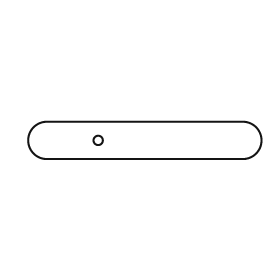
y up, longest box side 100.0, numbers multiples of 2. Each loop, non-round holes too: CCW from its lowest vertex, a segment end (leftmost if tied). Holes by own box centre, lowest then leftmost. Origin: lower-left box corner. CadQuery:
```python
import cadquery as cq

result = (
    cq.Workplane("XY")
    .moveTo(8.0, 0.0)
    .lineTo(92.0, 0.0)
    .threePointArc((100.0, 8.0), (92.0, 16.0))
    .lineTo(8.0, 16.0)
    .threePointArc((0.0, 8.0), (8.0, 0.0))
    .close()
    .moveTo(30.0, 8.0)
    .circle(2.0)
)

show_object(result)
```